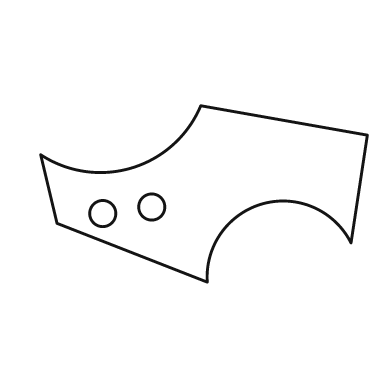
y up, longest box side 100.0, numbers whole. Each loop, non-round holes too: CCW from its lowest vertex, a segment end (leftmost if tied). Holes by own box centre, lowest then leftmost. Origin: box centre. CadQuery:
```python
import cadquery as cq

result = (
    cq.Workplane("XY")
    .moveTo(1.0, -27.0)
    .threePointArc((18.0, -3.0), (45.0, -15.0))
    .lineTo(50.0, 18.0)
    .lineTo(-1.0, 27.0)
    .threePointArc((-22.0, 8.0), (-50.0, 12.0))
    .lineTo(-45.0, -9.0)
    .close()
    .moveTo(-31.0, -6.0)
    .circle(4.0)
    .moveTo(-16.0, -4.0)
    .circle(4.0)
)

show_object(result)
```